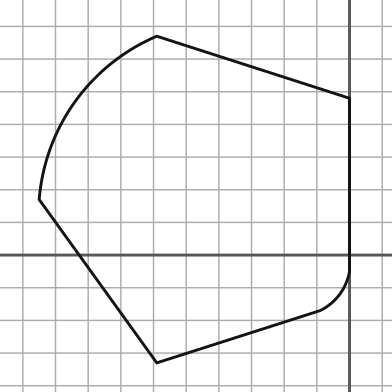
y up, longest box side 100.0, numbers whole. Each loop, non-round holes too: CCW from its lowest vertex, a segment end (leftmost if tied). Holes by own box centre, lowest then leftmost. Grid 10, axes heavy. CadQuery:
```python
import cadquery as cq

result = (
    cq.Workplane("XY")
    .moveTo(-59.0, -33.0)
    .lineTo(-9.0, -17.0)
    .threePointArc((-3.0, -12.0), (0.0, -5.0))
    .lineTo(0.0, 48.0)
    .lineTo(-59.0, 67.0)
    .threePointArc((-84.0, 47.0), (-95.0, 17.0))
    .close()
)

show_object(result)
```